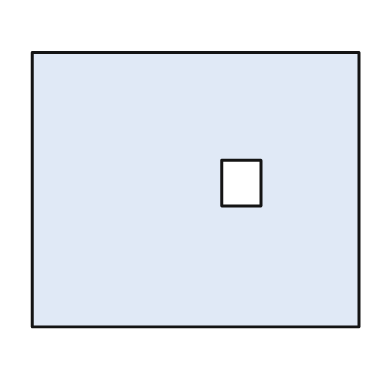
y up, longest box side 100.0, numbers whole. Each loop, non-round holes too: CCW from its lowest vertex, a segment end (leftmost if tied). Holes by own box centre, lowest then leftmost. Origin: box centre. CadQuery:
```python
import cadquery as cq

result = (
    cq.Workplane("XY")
    .moveTo(-50.0, -42.0)
    .lineTo(50.0, -42.0)
    .lineTo(50.0, 42.0)
    .lineTo(-50.0, 42.0)
    .close()
    .moveTo(8.0, -5.0)
    .lineTo(20.0, -5.0)
    .lineTo(20.0, 9.0)
    .lineTo(8.0, 9.0)
    .close()
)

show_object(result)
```